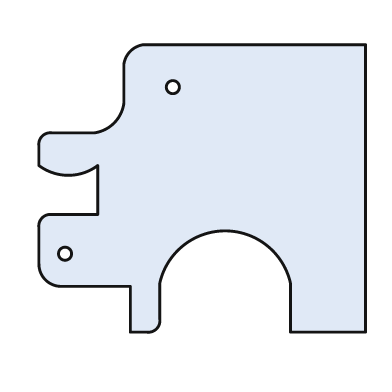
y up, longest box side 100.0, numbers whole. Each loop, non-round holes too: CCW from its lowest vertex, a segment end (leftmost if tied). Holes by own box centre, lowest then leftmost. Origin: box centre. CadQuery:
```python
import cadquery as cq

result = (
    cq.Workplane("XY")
    .moveTo(-22.0, -44.0)
    .lineTo(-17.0, -44.0)
    .threePointArc((-14.0, -43.0), (-13.0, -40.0))
    .lineTo(-13.0, -29.0)
    .threePointArc((7.0, -13.0), (27.0, -29.0))
    .lineTo(27.0, -44.0)
    .lineTo(50.0, -44.0)
    .lineTo(50.0, 44.0)
    .lineTo(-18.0, 44.0)
    .threePointArc((-22.0, 42.0), (-24.0, 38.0))
    .lineTo(-24.0, 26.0)
    .threePointArc((-27.0, 20.0), (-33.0, 17.0))
    .lineTo(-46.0, 17.0)
    .threePointArc((-49.0, 16.0), (-50.0, 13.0))
    .lineTo(-50.0, 7.0)
    .threePointArc((-41.0, 4.0), (-32.0, 7.0))
    .lineTo(-32.0, -8.0)
    .lineTo(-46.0, -8.0)
    .threePointArc((-49.0, -9.0), (-50.0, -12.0))
    .lineTo(-50.0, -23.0)
    .threePointArc((-48.0, -28.0), (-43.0, -30.0))
    .lineTo(-22.0, -30.0)
    .close()
    .moveTo(-42.0, -20.0)
    .circle(2.0)
    .moveTo(-9.0, 31.0)
    .circle(2.0)
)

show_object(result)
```